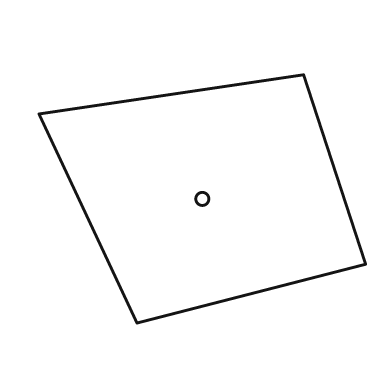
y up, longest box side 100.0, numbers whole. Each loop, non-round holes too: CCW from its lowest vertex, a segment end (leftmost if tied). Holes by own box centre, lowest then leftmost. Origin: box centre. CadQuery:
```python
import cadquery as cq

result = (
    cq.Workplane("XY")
    .moveTo(-20.0, -38.0)
    .lineTo(50.0, -20.0)
    .lineTo(31.0, 38.0)
    .lineTo(-50.0, 26.0)
    .close()
    .moveTo(0.0, 0.0)
    .circle(2.0)
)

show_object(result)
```